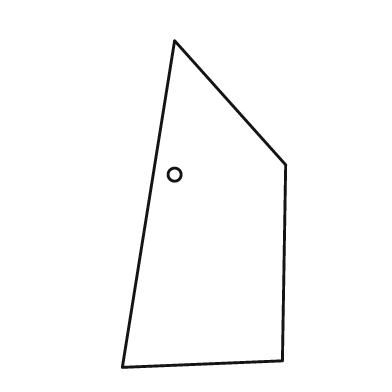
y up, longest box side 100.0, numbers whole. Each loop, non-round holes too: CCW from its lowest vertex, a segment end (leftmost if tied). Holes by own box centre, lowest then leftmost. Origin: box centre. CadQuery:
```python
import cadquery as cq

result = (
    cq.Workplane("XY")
    .moveTo(-25.0, -50.0)
    .lineTo(24.0, -48.0)
    .lineTo(25.0, 12.0)
    .lineTo(-9.0, 50.0)
    .close()
    .moveTo(-9.0, 9.0)
    .circle(2.0)
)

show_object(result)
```